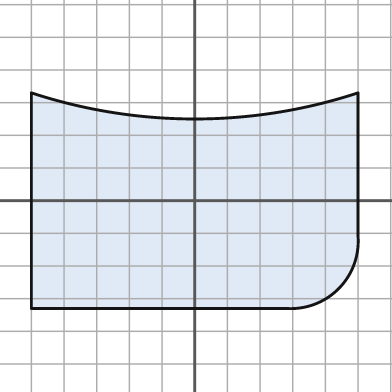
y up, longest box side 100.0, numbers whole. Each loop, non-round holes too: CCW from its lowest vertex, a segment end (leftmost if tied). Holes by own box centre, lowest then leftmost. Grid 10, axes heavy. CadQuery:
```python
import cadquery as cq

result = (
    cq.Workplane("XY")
    .moveTo(-50.0, -33.0)
    .lineTo(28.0, -33.0)
    .threePointArc((44.0, -27.0), (50.0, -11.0))
    .lineTo(50.0, 33.0)
    .threePointArc((0.0, 25.0), (-50.0, 33.0))
    .close()
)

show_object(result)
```